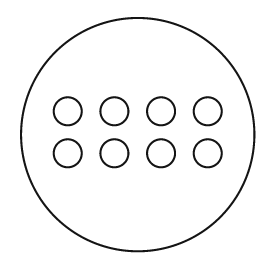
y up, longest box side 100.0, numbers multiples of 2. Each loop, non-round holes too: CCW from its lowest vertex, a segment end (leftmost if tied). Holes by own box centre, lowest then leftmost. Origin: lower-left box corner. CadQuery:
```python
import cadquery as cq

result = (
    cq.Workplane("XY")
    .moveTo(50.0, 50.0)
    .circle(50.0)
    .moveTo(20.0, 42.0)
    .circle(6.0)
    .moveTo(40.0, 42.0)
    .circle(6.0)
    .moveTo(60.0, 42.0)
    .circle(6.0)
    .moveTo(80.0, 42.0)
    .circle(6.0)
    .moveTo(20.0, 60.0)
    .circle(6.0)
    .moveTo(40.0, 60.0)
    .circle(6.0)
    .moveTo(60.0, 60.0)
    .circle(6.0)
    .moveTo(80.0, 60.0)
    .circle(6.0)
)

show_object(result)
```